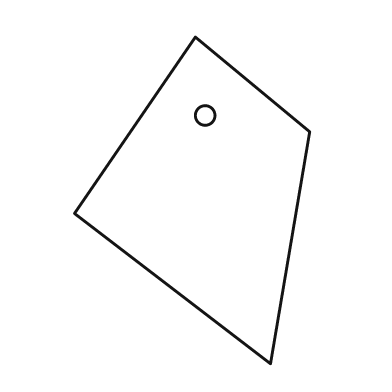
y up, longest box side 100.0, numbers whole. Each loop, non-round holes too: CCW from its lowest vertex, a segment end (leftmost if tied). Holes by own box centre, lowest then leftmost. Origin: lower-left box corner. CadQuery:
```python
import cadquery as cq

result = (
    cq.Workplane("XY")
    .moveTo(60.0, 0.0)
    .lineTo(72.0, 71.0)
    .lineTo(37.0, 100.0)
    .lineTo(0.0, 46.0)
    .close()
    .moveTo(40.0, 76.0)
    .circle(3.0)
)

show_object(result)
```